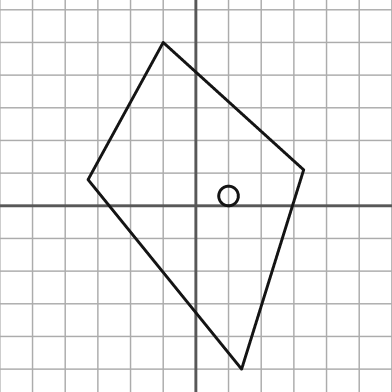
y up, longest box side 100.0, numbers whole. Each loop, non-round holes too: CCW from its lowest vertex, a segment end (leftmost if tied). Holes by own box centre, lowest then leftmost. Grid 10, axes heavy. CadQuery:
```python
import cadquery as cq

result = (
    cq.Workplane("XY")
    .moveTo(14.0, -50.0)
    .lineTo(33.0, 11.0)
    .lineTo(-10.0, 50.0)
    .lineTo(-33.0, 8.0)
    .close()
    .moveTo(10.0, 3.0)
    .circle(3.0)
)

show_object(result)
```